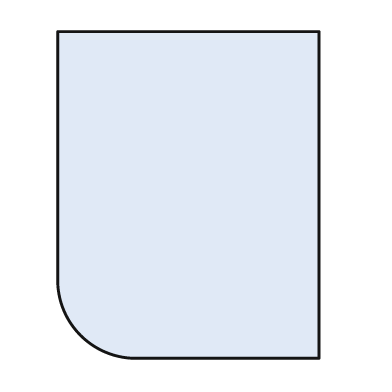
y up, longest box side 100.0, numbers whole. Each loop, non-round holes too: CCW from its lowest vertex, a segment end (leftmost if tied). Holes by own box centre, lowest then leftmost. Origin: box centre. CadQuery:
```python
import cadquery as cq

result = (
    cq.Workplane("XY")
    .moveTo(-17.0, -50.0)
    .lineTo(40.0, -50.0)
    .lineTo(40.0, 50.0)
    .lineTo(-40.0, 50.0)
    .lineTo(-40.0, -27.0)
    .threePointArc((-33.0, -43.0), (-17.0, -50.0))
    .close()
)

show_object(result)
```